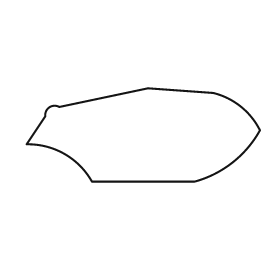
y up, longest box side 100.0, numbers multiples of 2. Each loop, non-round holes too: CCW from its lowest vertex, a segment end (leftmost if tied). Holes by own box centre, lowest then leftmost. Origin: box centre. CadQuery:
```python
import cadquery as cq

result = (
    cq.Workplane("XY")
    .moveTo(-22.0, -20.0)
    .lineTo(22.0, -20.0)
    .threePointArc((38.0, -12.0), (50.0, 2.0))
    .threePointArc((42.0, 12.0), (30.0, 18.0))
    .lineTo(2.0, 20.0)
    .lineTo(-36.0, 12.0)
    .threePointArc((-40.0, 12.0), (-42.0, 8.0))
    .lineTo(-50.0, -4.0)
    .threePointArc((-34.0, -8.0), (-22.0, -20.0))
    .close()
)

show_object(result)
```